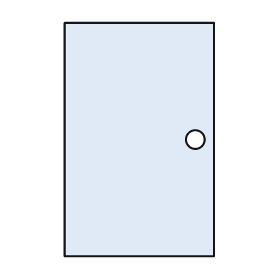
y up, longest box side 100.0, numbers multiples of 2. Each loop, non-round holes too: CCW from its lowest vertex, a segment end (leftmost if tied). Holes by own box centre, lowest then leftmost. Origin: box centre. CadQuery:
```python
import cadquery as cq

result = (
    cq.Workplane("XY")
    .moveTo(-32.0, -50.0)
    .lineTo(32.0, -50.0)
    .lineTo(32.0, 50.0)
    .lineTo(-32.0, 50.0)
    .close()
    .moveTo(24.0, 0.0)
    .circle(4.0)
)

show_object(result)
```